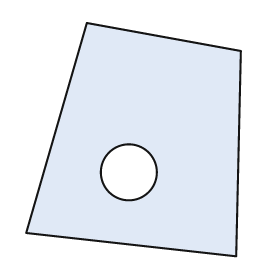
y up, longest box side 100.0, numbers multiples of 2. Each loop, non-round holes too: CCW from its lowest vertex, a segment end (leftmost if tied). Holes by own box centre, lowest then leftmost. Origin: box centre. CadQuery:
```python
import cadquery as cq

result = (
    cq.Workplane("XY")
    .moveTo(44.0, -50.0)
    .lineTo(46.0, 38.0)
    .lineTo(-20.0, 50.0)
    .lineTo(-46.0, -40.0)
    .close()
    .moveTo(-2.0, -14.0)
    .circle(12.0)
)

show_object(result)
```